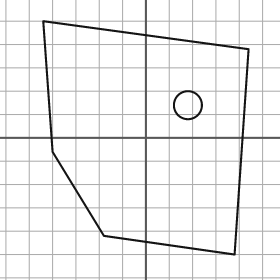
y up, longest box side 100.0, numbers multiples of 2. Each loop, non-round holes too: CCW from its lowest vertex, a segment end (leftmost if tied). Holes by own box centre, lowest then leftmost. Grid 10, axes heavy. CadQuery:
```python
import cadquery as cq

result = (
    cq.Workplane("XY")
    .moveTo(38.0, -50.0)
    .lineTo(44.0, 38.0)
    .lineTo(-44.0, 50.0)
    .lineTo(-40.0, -6.0)
    .lineTo(-18.0, -42.0)
    .close()
    .moveTo(18.0, 14.0)
    .circle(6.0)
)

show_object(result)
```